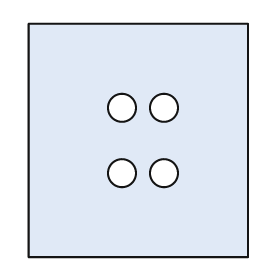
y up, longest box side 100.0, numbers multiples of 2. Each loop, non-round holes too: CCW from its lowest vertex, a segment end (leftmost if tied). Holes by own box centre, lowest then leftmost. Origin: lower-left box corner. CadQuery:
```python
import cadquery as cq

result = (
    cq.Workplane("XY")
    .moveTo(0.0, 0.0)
    .lineTo(94.0, 0.0)
    .lineTo(94.0, 100.0)
    .lineTo(0.0, 100.0)
    .close()
    .moveTo(40.0, 36.0)
    .circle(6.0)
    .moveTo(58.0, 36.0)
    .circle(6.0)
    .moveTo(40.0, 64.0)
    .circle(6.0)
    .moveTo(58.0, 64.0)
    .circle(6.0)
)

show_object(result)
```